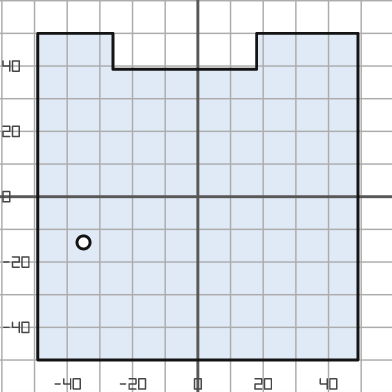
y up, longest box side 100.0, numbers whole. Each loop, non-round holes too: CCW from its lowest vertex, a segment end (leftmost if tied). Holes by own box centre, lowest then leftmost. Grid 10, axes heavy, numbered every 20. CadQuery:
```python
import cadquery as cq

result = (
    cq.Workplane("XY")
    .moveTo(-49.0, -50.0)
    .lineTo(49.0, -50.0)
    .lineTo(49.0, 50.0)
    .lineTo(18.0, 50.0)
    .lineTo(18.0, 39.0)
    .lineTo(-26.0, 39.0)
    .lineTo(-26.0, 50.0)
    .lineTo(-49.0, 50.0)
    .close()
    .moveTo(-35.0, -14.0)
    .circle(2.0)
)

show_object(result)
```